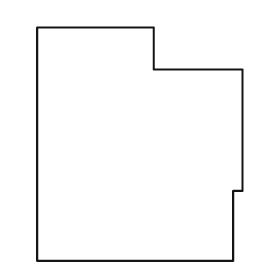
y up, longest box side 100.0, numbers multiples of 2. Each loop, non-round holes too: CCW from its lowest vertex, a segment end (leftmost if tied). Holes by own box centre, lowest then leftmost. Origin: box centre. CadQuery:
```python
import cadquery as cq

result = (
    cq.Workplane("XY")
    .moveTo(-44.0, -50.0)
    .lineTo(40.0, -50.0)
    .lineTo(40.0, -20.0)
    .lineTo(44.0, -20.0)
    .lineTo(44.0, 32.0)
    .lineTo(6.0, 32.0)
    .lineTo(6.0, 50.0)
    .lineTo(-44.0, 50.0)
    .close()
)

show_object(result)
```